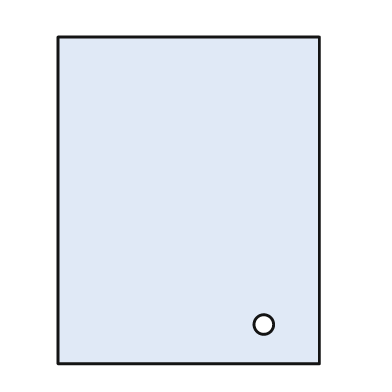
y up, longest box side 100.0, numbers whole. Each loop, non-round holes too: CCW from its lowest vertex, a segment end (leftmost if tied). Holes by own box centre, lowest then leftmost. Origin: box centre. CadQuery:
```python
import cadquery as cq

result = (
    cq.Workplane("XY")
    .moveTo(-40.0, -50.0)
    .lineTo(40.0, -50.0)
    .lineTo(40.0, 50.0)
    .lineTo(-40.0, 50.0)
    .close()
    .moveTo(23.0, -38.0)
    .circle(3.0)
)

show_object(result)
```